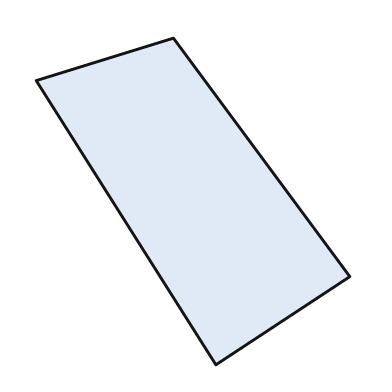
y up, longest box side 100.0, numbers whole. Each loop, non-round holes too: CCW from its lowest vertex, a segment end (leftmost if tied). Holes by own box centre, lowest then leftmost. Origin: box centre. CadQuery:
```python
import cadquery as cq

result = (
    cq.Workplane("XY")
    .moveTo(7.0, -50.0)
    .lineTo(48.0, -23.0)
    .lineTo(-6.0, 50.0)
    .lineTo(-48.0, 37.0)
    .close()
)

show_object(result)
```